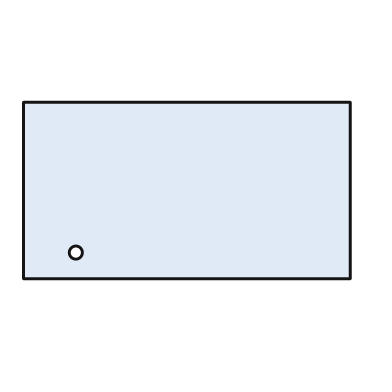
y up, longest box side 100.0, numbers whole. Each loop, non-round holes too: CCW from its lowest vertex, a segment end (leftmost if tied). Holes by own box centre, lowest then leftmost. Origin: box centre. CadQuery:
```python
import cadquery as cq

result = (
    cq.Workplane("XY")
    .moveTo(-50.0, -27.0)
    .lineTo(50.0, -27.0)
    .lineTo(50.0, 27.0)
    .lineTo(-50.0, 27.0)
    .close()
    .moveTo(-34.0, -19.0)
    .circle(2.0)
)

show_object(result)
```